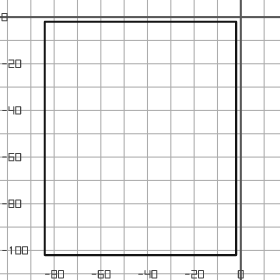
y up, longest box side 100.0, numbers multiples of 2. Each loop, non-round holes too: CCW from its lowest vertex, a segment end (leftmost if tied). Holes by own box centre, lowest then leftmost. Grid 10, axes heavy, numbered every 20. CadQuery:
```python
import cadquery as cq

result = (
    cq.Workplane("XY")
    .moveTo(-84.0, -102.0)
    .lineTo(-2.0, -102.0)
    .lineTo(-2.0, -2.0)
    .lineTo(-84.0, -2.0)
    .close()
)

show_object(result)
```